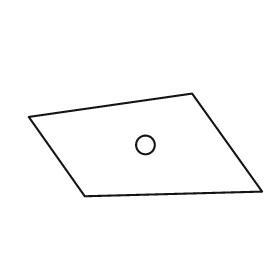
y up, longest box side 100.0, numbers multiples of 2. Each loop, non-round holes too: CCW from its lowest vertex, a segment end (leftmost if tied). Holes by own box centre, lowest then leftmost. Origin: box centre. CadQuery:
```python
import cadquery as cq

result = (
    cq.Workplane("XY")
    .moveTo(-26.0, -22.0)
    .lineTo(50.0, -20.0)
    .lineTo(20.0, 22.0)
    .lineTo(-50.0, 12.0)
    .close()
    .moveTo(0.0, 0.0)
    .circle(4.0)
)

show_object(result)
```